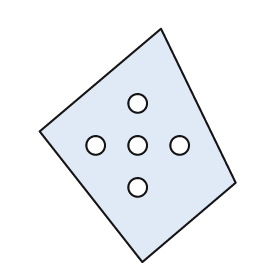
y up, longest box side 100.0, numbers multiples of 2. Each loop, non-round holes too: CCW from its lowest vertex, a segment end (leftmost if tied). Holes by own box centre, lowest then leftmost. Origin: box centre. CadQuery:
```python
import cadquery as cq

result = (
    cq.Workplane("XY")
    .moveTo(2.0, -50.0)
    .lineTo(42.0, -16.0)
    .lineTo(10.0, 50.0)
    .lineTo(-42.0, 6.0)
    .close()
    .moveTo(0.0, -18.0)
    .circle(4.0)
    .moveTo(-18.0, 0.0)
    .circle(4.0)
    .moveTo(0.0, 0.0)
    .circle(4.0)
    .moveTo(18.0, 0.0)
    .circle(4.0)
    .moveTo(0.0, 18.0)
    .circle(4.0)
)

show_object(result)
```